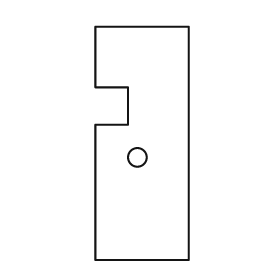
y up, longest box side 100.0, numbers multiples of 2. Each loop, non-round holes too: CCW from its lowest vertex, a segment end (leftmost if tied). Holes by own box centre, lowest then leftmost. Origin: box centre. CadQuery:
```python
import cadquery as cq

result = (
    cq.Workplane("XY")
    .moveTo(-20.0, -50.0)
    .lineTo(20.0, -50.0)
    .lineTo(20.0, 50.0)
    .lineTo(-20.0, 50.0)
    .lineTo(-20.0, 24.0)
    .lineTo(-6.0, 24.0)
    .lineTo(-6.0, 8.0)
    .lineTo(-20.0, 8.0)
    .close()
    .moveTo(-2.0, -6.0)
    .circle(4.0)
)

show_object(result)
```